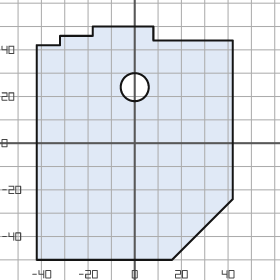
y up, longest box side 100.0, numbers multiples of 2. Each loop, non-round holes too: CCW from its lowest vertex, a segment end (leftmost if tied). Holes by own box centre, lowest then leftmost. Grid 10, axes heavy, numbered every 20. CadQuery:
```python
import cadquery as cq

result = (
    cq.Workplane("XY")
    .moveTo(-42.0, -50.0)
    .lineTo(16.0, -50.0)
    .lineTo(42.0, -24.0)
    .lineTo(42.0, 44.0)
    .lineTo(8.0, 44.0)
    .lineTo(8.0, 50.0)
    .lineTo(-18.0, 50.0)
    .lineTo(-18.0, 46.0)
    .lineTo(-32.0, 46.0)
    .lineTo(-32.0, 42.0)
    .lineTo(-42.0, 42.0)
    .close()
    .moveTo(0.0, 24.0)
    .circle(6.0)
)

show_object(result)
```